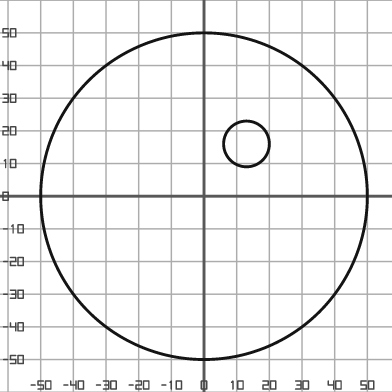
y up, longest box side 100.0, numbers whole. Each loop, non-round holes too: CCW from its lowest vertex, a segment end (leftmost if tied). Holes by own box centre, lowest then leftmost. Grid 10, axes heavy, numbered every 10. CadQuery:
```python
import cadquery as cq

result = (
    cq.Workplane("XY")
    .moveTo(0.0, 0.0)
    .circle(50.0)
    .moveTo(13.0, 16.0)
    .circle(7.0)
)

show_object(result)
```